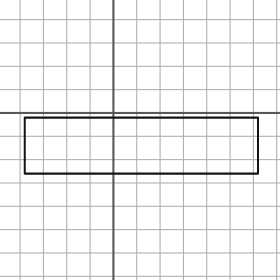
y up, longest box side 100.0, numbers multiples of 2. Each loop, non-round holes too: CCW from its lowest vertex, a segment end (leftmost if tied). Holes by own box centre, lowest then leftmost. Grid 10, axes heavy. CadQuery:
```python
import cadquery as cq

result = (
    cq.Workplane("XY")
    .moveTo(-38.0, -26.0)
    .lineTo(62.0, -26.0)
    .lineTo(62.0, -2.0)
    .lineTo(-38.0, -2.0)
    .close()
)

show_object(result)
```